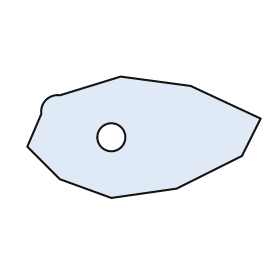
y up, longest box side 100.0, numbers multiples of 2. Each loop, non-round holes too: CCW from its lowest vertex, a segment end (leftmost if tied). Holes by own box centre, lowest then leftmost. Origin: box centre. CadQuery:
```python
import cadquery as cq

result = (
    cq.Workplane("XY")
    .moveTo(-14.0, -26.0)
    .lineTo(14.0, -22.0)
    .lineTo(42.0, -8.0)
    .lineTo(50.0, 8.0)
    .lineTo(20.0, 22.0)
    .lineTo(-10.0, 26.0)
    .lineTo(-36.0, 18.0)
    .threePointArc((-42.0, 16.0), (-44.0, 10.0))
    .lineTo(-50.0, -4.0)
    .lineTo(-36.0, -18.0)
    .close()
    .moveTo(-14.0, 0.0)
    .circle(6.0)
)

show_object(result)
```